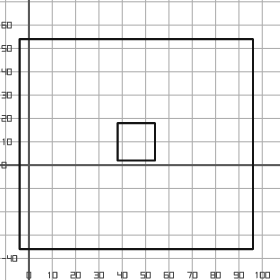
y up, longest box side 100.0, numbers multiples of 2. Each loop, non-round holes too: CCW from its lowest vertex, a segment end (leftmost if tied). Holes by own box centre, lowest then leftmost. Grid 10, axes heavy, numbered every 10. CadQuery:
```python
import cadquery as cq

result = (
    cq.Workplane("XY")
    .moveTo(-4.0, -36.0)
    .lineTo(96.0, -36.0)
    .lineTo(96.0, 54.0)
    .lineTo(-4.0, 54.0)
    .close()
    .moveTo(38.0, 2.0)
    .lineTo(54.0, 2.0)
    .lineTo(54.0, 18.0)
    .lineTo(38.0, 18.0)
    .close()
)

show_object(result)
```